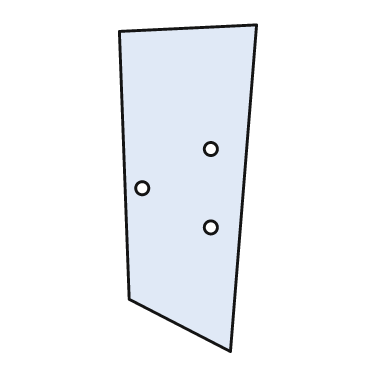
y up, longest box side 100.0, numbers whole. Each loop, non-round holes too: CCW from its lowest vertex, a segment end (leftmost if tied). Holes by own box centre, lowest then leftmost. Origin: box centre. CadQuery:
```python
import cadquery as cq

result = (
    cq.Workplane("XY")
    .moveTo(13.0, -50.0)
    .lineTo(21.0, 50.0)
    .lineTo(-21.0, 48.0)
    .lineTo(-18.0, -34.0)
    .close()
    .moveTo(7.0, -12.0)
    .circle(2.0)
    .moveTo(-14.0, 0.0)
    .circle(2.0)
    .moveTo(7.0, 12.0)
    .circle(2.0)
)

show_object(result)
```